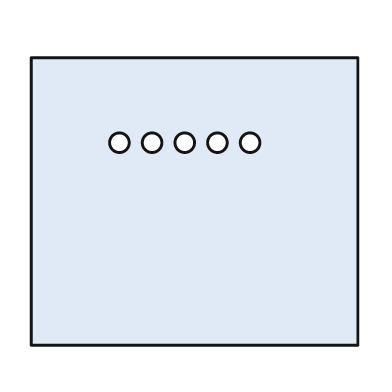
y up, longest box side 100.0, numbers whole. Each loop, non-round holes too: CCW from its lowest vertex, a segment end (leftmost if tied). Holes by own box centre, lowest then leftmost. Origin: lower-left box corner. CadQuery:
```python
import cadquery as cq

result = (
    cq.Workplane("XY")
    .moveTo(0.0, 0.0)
    .lineTo(100.0, 0.0)
    .lineTo(100.0, 88.0)
    .lineTo(0.0, 88.0)
    .close()
    .moveTo(27.0, 62.0)
    .circle(3.0)
    .moveTo(37.0, 62.0)
    .circle(3.0)
    .moveTo(47.0, 62.0)
    .circle(3.0)
    .moveTo(57.0, 62.0)
    .circle(3.0)
    .moveTo(67.0, 62.0)
    .circle(3.0)
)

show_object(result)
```